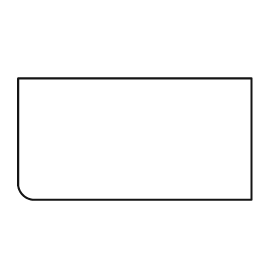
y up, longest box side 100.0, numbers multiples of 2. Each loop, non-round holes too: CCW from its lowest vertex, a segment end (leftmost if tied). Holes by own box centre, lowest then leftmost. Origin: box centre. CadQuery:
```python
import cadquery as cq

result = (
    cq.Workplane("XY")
    .moveTo(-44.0, -26.0)
    .lineTo(50.0, -26.0)
    .lineTo(50.0, 26.0)
    .lineTo(-50.0, 26.0)
    .lineTo(-50.0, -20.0)
    .threePointArc((-48.0, -24.0), (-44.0, -26.0))
    .close()
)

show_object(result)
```